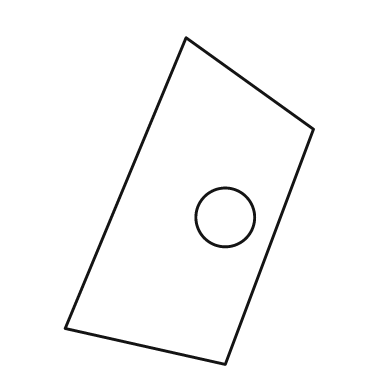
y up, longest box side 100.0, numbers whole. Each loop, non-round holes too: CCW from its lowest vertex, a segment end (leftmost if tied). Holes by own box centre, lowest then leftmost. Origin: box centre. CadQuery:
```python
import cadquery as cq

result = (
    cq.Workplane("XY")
    .moveTo(11.0, -50.0)
    .lineTo(38.0, 22.0)
    .lineTo(-1.0, 50.0)
    .lineTo(-38.0, -39.0)
    .close()
    .moveTo(11.0, -5.0)
    .circle(9.0)
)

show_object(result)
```